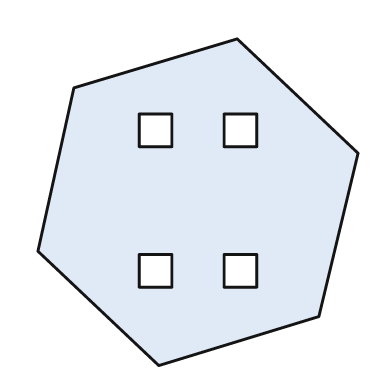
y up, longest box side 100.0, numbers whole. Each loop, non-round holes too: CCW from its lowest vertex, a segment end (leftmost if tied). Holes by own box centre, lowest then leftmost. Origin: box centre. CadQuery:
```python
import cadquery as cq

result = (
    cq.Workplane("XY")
    .moveTo(-12.0, -50.0)
    .lineTo(37.0, -35.0)
    .lineTo(49.0, 15.0)
    .lineTo(12.0, 50.0)
    .lineTo(-38.0, 35.0)
    .lineTo(-49.0, -15.0)
    .close()
    .moveTo(-18.0, -26.0)
    .lineTo(-8.0, -26.0)
    .lineTo(-8.0, -16.0)
    .lineTo(-18.0, -16.0)
    .close()
    .moveTo(8.0, -26.0)
    .lineTo(18.0, -26.0)
    .lineTo(18.0, -16.0)
    .lineTo(8.0, -16.0)
    .close()
    .moveTo(-18.0, 17.0)
    .lineTo(-8.0, 17.0)
    .lineTo(-8.0, 27.0)
    .lineTo(-18.0, 27.0)
    .close()
    .moveTo(8.0, 17.0)
    .lineTo(18.0, 17.0)
    .lineTo(18.0, 27.0)
    .lineTo(8.0, 27.0)
    .close()
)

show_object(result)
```